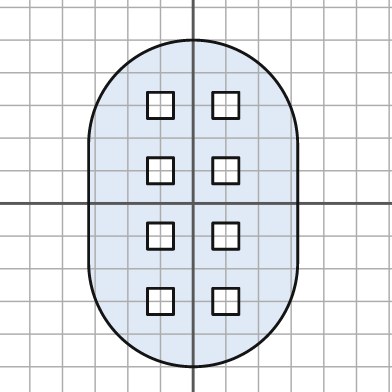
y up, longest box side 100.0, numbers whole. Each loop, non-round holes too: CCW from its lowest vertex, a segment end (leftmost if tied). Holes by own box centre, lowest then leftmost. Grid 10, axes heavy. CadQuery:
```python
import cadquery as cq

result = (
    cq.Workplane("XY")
    .moveTo(-32.0, -18.0)
    .threePointArc((0.0, -50.0), (32.0, -18.0))
    .lineTo(32.0, 18.0)
    .threePointArc((0.0, 50.0), (-32.0, 18.0))
    .close()
    .moveTo(-14.0, -34.0)
    .lineTo(-6.0, -34.0)
    .lineTo(-6.0, -26.0)
    .lineTo(-14.0, -26.0)
    .close()
    .moveTo(6.0, -34.0)
    .lineTo(14.0, -34.0)
    .lineTo(14.0, -26.0)
    .lineTo(6.0, -26.0)
    .close()
    .moveTo(-14.0, -14.0)
    .lineTo(-6.0, -14.0)
    .lineTo(-6.0, -6.0)
    .lineTo(-14.0, -6.0)
    .close()
    .moveTo(6.0, -14.0)
    .lineTo(14.0, -14.0)
    .lineTo(14.0, -6.0)
    .lineTo(6.0, -6.0)
    .close()
    .moveTo(-14.0, 6.0)
    .lineTo(-6.0, 6.0)
    .lineTo(-6.0, 14.0)
    .lineTo(-14.0, 14.0)
    .close()
    .moveTo(6.0, 6.0)
    .lineTo(14.0, 6.0)
    .lineTo(14.0, 14.0)
    .lineTo(6.0, 14.0)
    .close()
    .moveTo(-14.0, 26.0)
    .lineTo(-6.0, 26.0)
    .lineTo(-6.0, 34.0)
    .lineTo(-14.0, 34.0)
    .close()
    .moveTo(6.0, 26.0)
    .lineTo(14.0, 26.0)
    .lineTo(14.0, 34.0)
    .lineTo(6.0, 34.0)
    .close()
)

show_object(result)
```